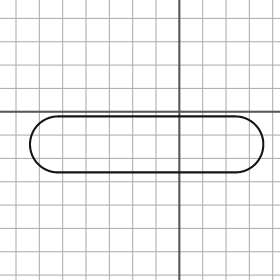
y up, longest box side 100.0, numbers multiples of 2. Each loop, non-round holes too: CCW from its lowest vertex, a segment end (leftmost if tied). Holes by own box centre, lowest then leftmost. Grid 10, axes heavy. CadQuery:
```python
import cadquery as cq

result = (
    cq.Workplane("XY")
    .moveTo(-52.0, -26.0)
    .lineTo(24.0, -26.0)
    .threePointArc((36.0, -14.0), (24.0, -2.0))
    .lineTo(-52.0, -2.0)
    .threePointArc((-64.0, -14.0), (-52.0, -26.0))
    .close()
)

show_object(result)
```